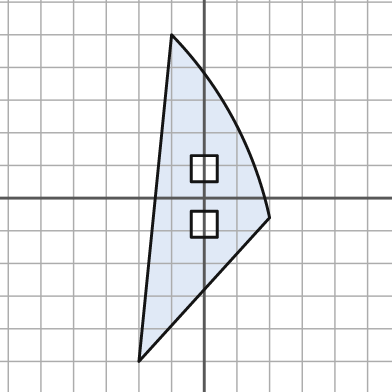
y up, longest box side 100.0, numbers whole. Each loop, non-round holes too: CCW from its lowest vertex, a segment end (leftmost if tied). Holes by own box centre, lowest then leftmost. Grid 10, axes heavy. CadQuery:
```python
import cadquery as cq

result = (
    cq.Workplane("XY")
    .moveTo(-20.0, -50.0)
    .lineTo(20.0, -6.0)
    .threePointArc((9.0, 24.0), (-10.0, 50.0))
    .close()
    .moveTo(-4.0, -12.0)
    .lineTo(4.0, -12.0)
    .lineTo(4.0, -4.0)
    .lineTo(-4.0, -4.0)
    .close()
    .moveTo(-4.0, 5.0)
    .lineTo(4.0, 5.0)
    .lineTo(4.0, 13.0)
    .lineTo(-4.0, 13.0)
    .close()
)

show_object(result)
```